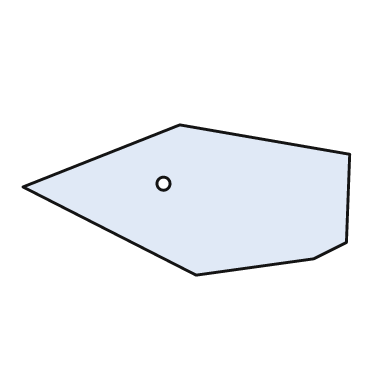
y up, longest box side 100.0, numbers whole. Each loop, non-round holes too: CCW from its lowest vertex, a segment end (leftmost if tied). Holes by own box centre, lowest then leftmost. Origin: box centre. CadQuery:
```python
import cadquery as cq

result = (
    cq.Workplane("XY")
    .moveTo(3.0, -23.0)
    .lineTo(39.0, -18.0)
    .lineTo(49.0, -13.0)
    .lineTo(50.0, 14.0)
    .lineTo(-2.0, 23.0)
    .lineTo(-50.0, 4.0)
    .close()
    .moveTo(-7.0, 5.0)
    .circle(2.0)
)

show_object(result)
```